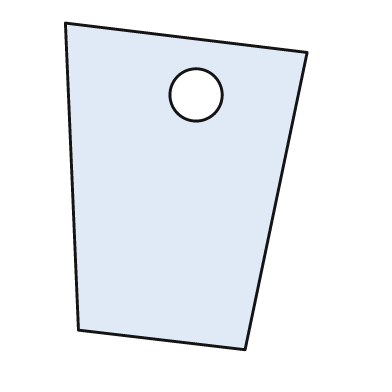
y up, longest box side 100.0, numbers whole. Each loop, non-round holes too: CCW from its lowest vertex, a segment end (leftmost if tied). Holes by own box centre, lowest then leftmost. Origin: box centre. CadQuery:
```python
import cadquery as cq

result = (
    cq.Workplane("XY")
    .moveTo(18.0, -50.0)
    .lineTo(37.0, 41.0)
    .lineTo(-37.0, 50.0)
    .lineTo(-33.0, -44.0)
    .close()
    .moveTo(3.0, 28.0)
    .circle(8.0)
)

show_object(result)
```